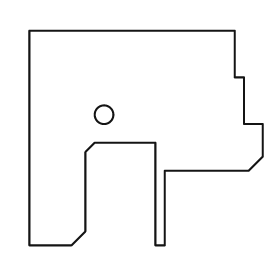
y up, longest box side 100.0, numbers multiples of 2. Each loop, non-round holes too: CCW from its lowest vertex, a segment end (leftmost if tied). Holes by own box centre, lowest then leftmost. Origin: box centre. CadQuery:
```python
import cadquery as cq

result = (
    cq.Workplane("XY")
    .moveTo(-50.0, -46.0)
    .lineTo(-32.0, -46.0)
    .lineTo(-26.0, -40.0)
    .lineTo(-26.0, -6.0)
    .lineTo(-22.0, -2.0)
    .lineTo(4.0, -2.0)
    .lineTo(4.0, -46.0)
    .lineTo(8.0, -46.0)
    .lineTo(8.0, -14.0)
    .lineTo(44.0, -14.0)
    .lineTo(50.0, -8.0)
    .lineTo(50.0, 6.0)
    .lineTo(42.0, 6.0)
    .lineTo(42.0, 26.0)
    .lineTo(38.0, 26.0)
    .lineTo(38.0, 46.0)
    .lineTo(-50.0, 46.0)
    .close()
    .moveTo(-18.0, 10.0)
    .circle(4.0)
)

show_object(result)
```